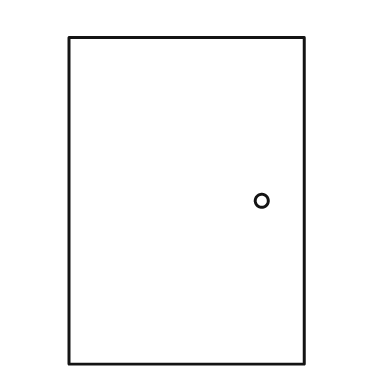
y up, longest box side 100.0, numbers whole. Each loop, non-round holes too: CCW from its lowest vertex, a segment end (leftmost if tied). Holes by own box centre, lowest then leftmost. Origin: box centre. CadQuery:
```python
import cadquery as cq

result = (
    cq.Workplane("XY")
    .moveTo(-36.0, -50.0)
    .lineTo(36.0, -50.0)
    .lineTo(36.0, 50.0)
    .lineTo(-36.0, 50.0)
    .close()
    .moveTo(23.0, 0.0)
    .circle(2.0)
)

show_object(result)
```